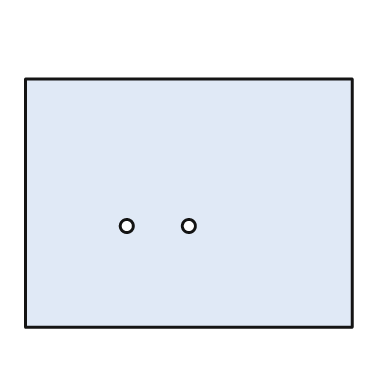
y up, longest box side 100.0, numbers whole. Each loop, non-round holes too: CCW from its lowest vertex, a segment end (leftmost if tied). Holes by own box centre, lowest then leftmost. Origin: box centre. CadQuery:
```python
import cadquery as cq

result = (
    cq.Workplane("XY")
    .moveTo(-50.0, -38.0)
    .lineTo(50.0, -38.0)
    .lineTo(50.0, 38.0)
    .lineTo(-50.0, 38.0)
    .close()
    .moveTo(-19.0, -7.0)
    .circle(2.0)
    .moveTo(0.0, -7.0)
    .circle(2.0)
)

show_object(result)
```